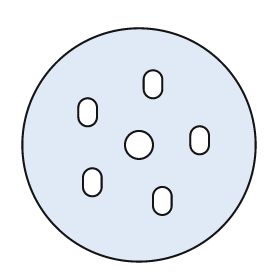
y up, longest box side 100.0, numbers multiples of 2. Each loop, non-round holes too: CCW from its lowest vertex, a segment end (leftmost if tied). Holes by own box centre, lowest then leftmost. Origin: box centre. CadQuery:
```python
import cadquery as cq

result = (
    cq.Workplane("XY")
    .moveTo(0.0, 0.0)
    .circle(50.0)
    .moveTo(6.0, -26.0)
    .threePointArc((10.0, -30.0), (14.0, -26.0))
    .lineTo(14.0, -22.0)
    .threePointArc((10.0, -18.0), (6.0, -22.0))
    .close()
    .moveTo(-24.0, -18.0)
    .threePointArc((-20.0, -22.0), (-16.0, -18.0))
    .lineTo(-16.0, -14.0)
    .threePointArc((-20.0, -10.0), (-24.0, -14.0))
    .close()
    .moveTo(0.0, 0.0)
    .circle(6.0)
    .moveTo(22.0, 0.0)
    .threePointArc((26.0, -4.0), (30.0, 0.0))
    .lineTo(30.0, 4.0)
    .threePointArc((26.0, 8.0), (22.0, 4.0))
    .close()
    .moveTo(-26.0, 12.0)
    .threePointArc((-22.0, 8.0), (-18.0, 12.0))
    .lineTo(-18.0, 16.0)
    .threePointArc((-22.0, 20.0), (-26.0, 16.0))
    .close()
    .moveTo(2.0, 24.0)
    .threePointArc((6.0, 20.0), (10.0, 24.0))
    .lineTo(10.0, 28.0)
    .threePointArc((6.0, 32.0), (2.0, 28.0))
    .close()
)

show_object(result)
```